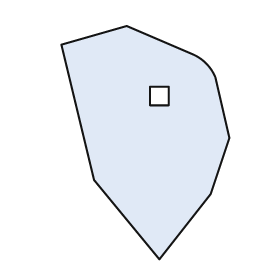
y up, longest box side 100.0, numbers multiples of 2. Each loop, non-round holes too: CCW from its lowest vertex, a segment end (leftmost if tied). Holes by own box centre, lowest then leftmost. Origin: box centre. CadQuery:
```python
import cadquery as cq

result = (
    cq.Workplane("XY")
    .moveTo(6.0, -50.0)
    .lineTo(28.0, -22.0)
    .lineTo(36.0, 2.0)
    .lineTo(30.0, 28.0)
    .threePointArc((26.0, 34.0), (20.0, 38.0))
    .lineTo(-8.0, 50.0)
    .lineTo(-36.0, 42.0)
    .lineTo(-22.0, -16.0)
    .close()
    .moveTo(2.0, 16.0)
    .lineTo(10.0, 16.0)
    .lineTo(10.0, 24.0)
    .lineTo(2.0, 24.0)
    .close()
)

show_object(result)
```